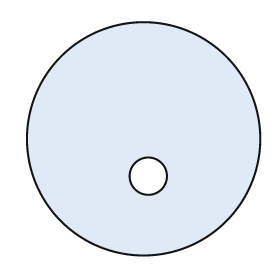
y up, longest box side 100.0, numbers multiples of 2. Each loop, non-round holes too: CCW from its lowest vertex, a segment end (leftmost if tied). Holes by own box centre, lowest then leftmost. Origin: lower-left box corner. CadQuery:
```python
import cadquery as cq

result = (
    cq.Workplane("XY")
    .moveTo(50.0, 50.0)
    .circle(50.0)
    .moveTo(52.0, 34.0)
    .circle(8.0)
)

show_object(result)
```